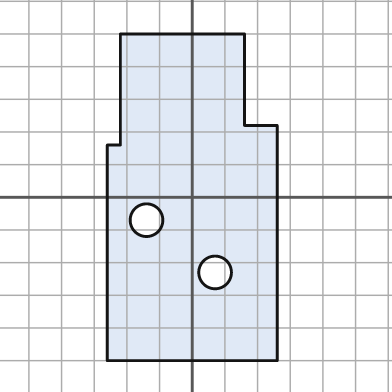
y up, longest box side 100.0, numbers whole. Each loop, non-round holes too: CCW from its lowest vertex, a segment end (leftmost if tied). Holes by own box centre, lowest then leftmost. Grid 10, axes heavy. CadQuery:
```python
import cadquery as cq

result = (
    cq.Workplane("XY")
    .moveTo(-26.0, -50.0)
    .lineTo(26.0, -50.0)
    .lineTo(26.0, 22.0)
    .lineTo(16.0, 22.0)
    .lineTo(16.0, 50.0)
    .lineTo(-22.0, 50.0)
    .lineTo(-22.0, 16.0)
    .lineTo(-26.0, 16.0)
    .close()
    .moveTo(7.0, -23.0)
    .circle(5.0)
    .moveTo(-14.0, -7.0)
    .circle(5.0)
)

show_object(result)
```